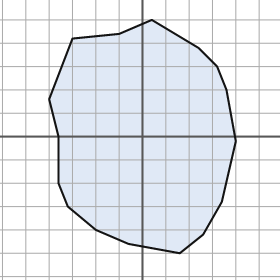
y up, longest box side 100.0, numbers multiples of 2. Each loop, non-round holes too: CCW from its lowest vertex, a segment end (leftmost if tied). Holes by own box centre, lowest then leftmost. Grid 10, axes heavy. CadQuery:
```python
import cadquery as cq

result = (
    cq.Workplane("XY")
    .moveTo(16.0, -50.0)
    .lineTo(26.0, -42.0)
    .lineTo(34.0, -28.0)
    .lineTo(40.0, -2.0)
    .lineTo(36.0, 20.0)
    .lineTo(32.0, 30.0)
    .lineTo(24.0, 38.0)
    .lineTo(4.0, 50.0)
    .lineTo(-10.0, 44.0)
    .lineTo(-30.0, 42.0)
    .lineTo(-40.0, 16.0)
    .lineTo(-36.0, 0.0)
    .lineTo(-36.0, -20.0)
    .lineTo(-32.0, -30.0)
    .lineTo(-20.0, -40.0)
    .lineTo(-6.0, -46.0)
    .close()
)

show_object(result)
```